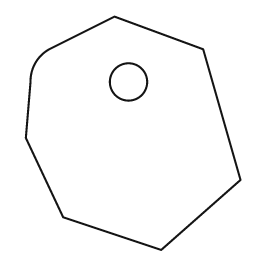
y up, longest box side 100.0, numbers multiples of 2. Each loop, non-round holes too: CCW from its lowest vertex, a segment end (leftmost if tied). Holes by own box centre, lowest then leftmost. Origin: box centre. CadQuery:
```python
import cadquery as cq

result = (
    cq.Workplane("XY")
    .moveTo(12.0, -50.0)
    .lineTo(46.0, -20.0)
    .lineTo(30.0, 36.0)
    .lineTo(-8.0, 50.0)
    .lineTo(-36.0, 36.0)
    .threePointArc((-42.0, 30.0), (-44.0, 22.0))
    .lineTo(-46.0, -2.0)
    .lineTo(-30.0, -36.0)
    .close()
    .moveTo(-2.0, 22.0)
    .circle(8.0)
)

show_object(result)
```